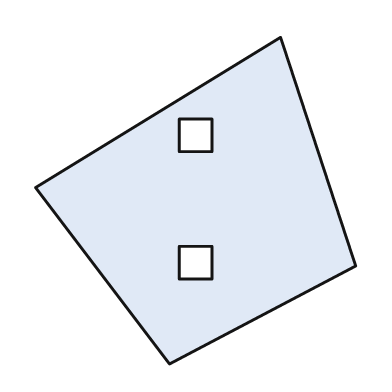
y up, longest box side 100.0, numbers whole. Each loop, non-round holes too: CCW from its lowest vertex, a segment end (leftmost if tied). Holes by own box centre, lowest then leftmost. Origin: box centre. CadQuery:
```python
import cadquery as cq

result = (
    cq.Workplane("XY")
    .moveTo(-8.0, -50.0)
    .lineTo(49.0, -20.0)
    .lineTo(26.0, 50.0)
    .lineTo(-49.0, 4.0)
    .close()
    .moveTo(-5.0, -24.0)
    .lineTo(5.0, -24.0)
    .lineTo(5.0, -14.0)
    .lineTo(-5.0, -14.0)
    .close()
    .moveTo(-5.0, 15.0)
    .lineTo(5.0, 15.0)
    .lineTo(5.0, 25.0)
    .lineTo(-5.0, 25.0)
    .close()
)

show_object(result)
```